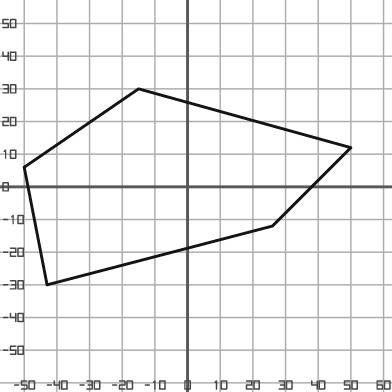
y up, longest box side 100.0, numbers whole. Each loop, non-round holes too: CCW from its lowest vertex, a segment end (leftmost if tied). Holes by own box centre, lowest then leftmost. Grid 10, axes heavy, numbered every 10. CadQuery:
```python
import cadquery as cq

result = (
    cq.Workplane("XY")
    .moveTo(-43.0, -30.0)
    .lineTo(26.0, -12.0)
    .lineTo(50.0, 12.0)
    .lineTo(-15.0, 30.0)
    .lineTo(-50.0, 6.0)
    .close()
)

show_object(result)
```